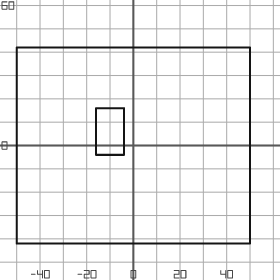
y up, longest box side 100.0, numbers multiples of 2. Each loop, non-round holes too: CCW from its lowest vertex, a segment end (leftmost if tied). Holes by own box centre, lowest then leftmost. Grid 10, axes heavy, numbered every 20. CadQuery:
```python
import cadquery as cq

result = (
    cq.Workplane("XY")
    .moveTo(-50.0, -42.0)
    .lineTo(50.0, -42.0)
    .lineTo(50.0, 42.0)
    .lineTo(-50.0, 42.0)
    .close()
    .moveTo(-16.0, -4.0)
    .lineTo(-4.0, -4.0)
    .lineTo(-4.0, 16.0)
    .lineTo(-16.0, 16.0)
    .close()
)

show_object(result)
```